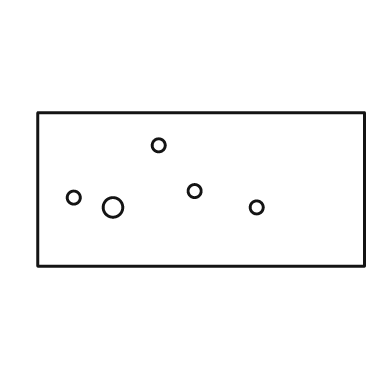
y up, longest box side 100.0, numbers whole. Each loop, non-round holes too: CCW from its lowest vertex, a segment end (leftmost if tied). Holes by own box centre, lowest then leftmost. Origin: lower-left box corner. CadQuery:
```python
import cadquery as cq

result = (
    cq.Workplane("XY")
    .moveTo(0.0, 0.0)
    .lineTo(100.0, 0.0)
    .lineTo(100.0, 47.0)
    .lineTo(0.0, 47.0)
    .close()
    .moveTo(23.0, 18.0)
    .circle(3.0)
    .moveTo(67.0, 18.0)
    .circle(2.0)
    .moveTo(11.0, 21.0)
    .circle(2.0)
    .moveTo(48.0, 23.0)
    .circle(2.0)
    .moveTo(37.0, 37.0)
    .circle(2.0)
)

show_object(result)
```